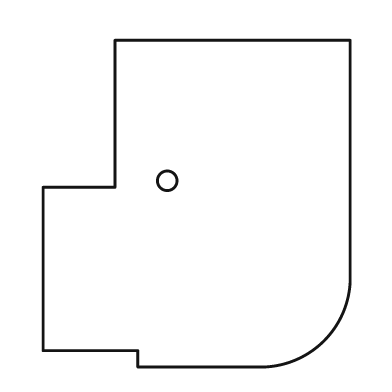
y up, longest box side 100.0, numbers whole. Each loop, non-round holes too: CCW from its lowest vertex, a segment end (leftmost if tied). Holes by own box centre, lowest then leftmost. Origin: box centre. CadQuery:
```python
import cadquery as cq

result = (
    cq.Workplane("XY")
    .moveTo(-18.0, -50.0)
    .lineTo(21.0, -50.0)
    .threePointArc((39.0, -42.0), (47.0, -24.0))
    .lineTo(47.0, 50.0)
    .lineTo(-25.0, 50.0)
    .lineTo(-25.0, 5.0)
    .lineTo(-47.0, 5.0)
    .lineTo(-47.0, -45.0)
    .lineTo(-18.0, -45.0)
    .close()
    .moveTo(-9.0, 7.0)
    .circle(3.0)
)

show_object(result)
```